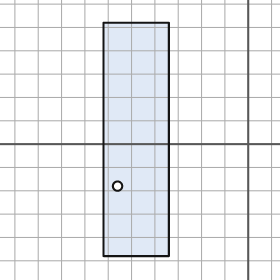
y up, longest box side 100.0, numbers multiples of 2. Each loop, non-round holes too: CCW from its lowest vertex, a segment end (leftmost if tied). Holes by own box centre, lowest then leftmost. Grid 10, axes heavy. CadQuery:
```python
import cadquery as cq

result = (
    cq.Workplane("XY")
    .moveTo(-62.0, -48.0)
    .lineTo(-34.0, -48.0)
    .lineTo(-34.0, 52.0)
    .lineTo(-62.0, 52.0)
    .close()
    .moveTo(-56.0, -18.0)
    .circle(2.0)
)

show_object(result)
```